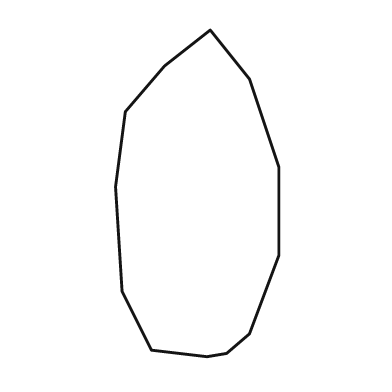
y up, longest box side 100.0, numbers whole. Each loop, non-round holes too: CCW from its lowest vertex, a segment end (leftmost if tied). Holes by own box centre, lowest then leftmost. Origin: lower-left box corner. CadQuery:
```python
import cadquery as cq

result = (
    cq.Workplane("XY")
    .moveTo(28.0, 0.0)
    .lineTo(34.0, 1.0)
    .lineTo(41.0, 7.0)
    .lineTo(50.0, 31.0)
    .lineTo(50.0, 58.0)
    .lineTo(41.0, 85.0)
    .lineTo(29.0, 100.0)
    .lineTo(15.0, 89.0)
    .lineTo(3.0, 75.0)
    .lineTo(0.0, 52.0)
    .lineTo(2.0, 20.0)
    .lineTo(11.0, 2.0)
    .close()
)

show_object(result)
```